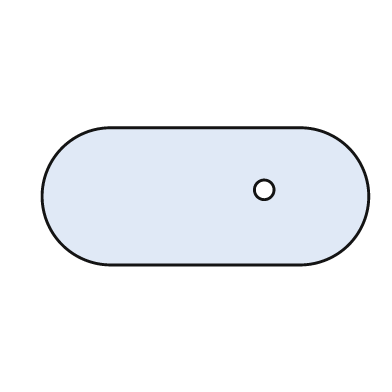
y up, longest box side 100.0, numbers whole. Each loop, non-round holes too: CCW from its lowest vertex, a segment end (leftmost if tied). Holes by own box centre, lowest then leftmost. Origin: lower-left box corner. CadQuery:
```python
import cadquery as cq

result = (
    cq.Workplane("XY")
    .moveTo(21.0, 0.0)
    .lineTo(79.0, 0.0)
    .threePointArc((100.0, 21.0), (79.0, 42.0))
    .lineTo(21.0, 42.0)
    .threePointArc((0.0, 21.0), (21.0, 0.0))
    .close()
    .moveTo(68.0, 23.0)
    .circle(3.0)
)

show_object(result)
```